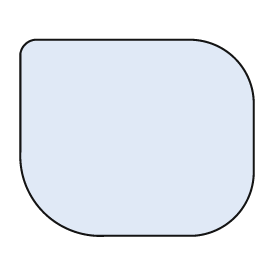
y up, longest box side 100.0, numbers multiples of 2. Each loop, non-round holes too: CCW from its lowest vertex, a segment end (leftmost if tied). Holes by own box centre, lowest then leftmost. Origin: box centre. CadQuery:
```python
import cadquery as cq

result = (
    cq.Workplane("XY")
    .moveTo(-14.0, -42.0)
    .lineTo(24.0, -42.0)
    .threePointArc((42.0, -34.0), (50.0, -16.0))
    .lineTo(50.0, 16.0)
    .threePointArc((42.0, 34.0), (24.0, 42.0))
    .lineTo(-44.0, 42.0)
    .threePointArc((-48.0, 40.0), (-50.0, 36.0))
    .lineTo(-50.0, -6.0)
    .threePointArc((-40.0, -32.0), (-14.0, -42.0))
    .close()
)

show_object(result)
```